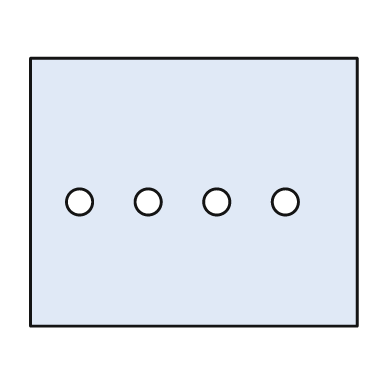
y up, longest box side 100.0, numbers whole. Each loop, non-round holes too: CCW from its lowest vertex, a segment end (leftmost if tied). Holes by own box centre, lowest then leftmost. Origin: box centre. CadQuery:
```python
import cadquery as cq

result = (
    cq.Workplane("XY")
    .moveTo(-50.0, -41.0)
    .lineTo(50.0, -41.0)
    .lineTo(50.0, 41.0)
    .lineTo(-50.0, 41.0)
    .close()
    .moveTo(-35.0, -3.0)
    .circle(4.0)
    .moveTo(-14.0, -3.0)
    .circle(4.0)
    .moveTo(7.0, -3.0)
    .circle(4.0)
    .moveTo(28.0, -3.0)
    .circle(4.0)
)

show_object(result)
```